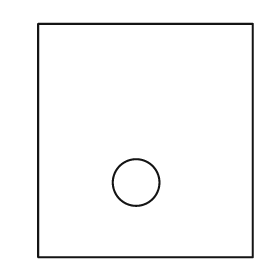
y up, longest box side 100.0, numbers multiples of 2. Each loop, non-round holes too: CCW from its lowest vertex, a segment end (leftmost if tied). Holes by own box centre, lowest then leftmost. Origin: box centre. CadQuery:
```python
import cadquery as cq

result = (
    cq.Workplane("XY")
    .moveTo(-46.0, -50.0)
    .lineTo(46.0, -50.0)
    .lineTo(46.0, 50.0)
    .lineTo(-46.0, 50.0)
    .close()
    .moveTo(-4.0, -18.0)
    .circle(10.0)
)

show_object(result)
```